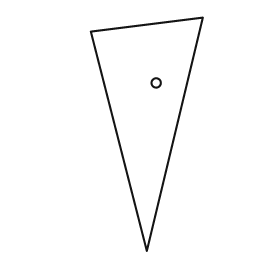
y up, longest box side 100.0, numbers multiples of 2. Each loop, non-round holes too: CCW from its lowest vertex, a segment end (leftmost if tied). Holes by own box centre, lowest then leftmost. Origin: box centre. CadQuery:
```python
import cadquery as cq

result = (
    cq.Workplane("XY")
    .moveTo(0.0, -50.0)
    .lineTo(24.0, 50.0)
    .lineTo(-24.0, 44.0)
    .close()
    .moveTo(4.0, 22.0)
    .circle(2.0)
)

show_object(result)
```